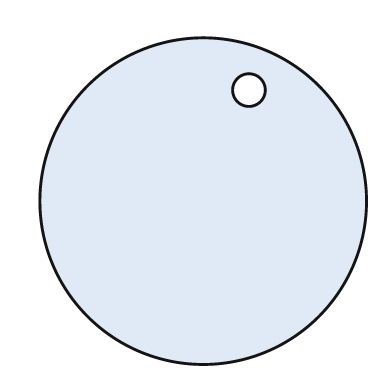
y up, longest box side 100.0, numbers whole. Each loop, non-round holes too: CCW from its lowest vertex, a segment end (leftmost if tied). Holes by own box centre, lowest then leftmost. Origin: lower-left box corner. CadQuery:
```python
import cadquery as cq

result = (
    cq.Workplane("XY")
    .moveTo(50.0, 50.0)
    .circle(50.0)
    .moveTo(64.0, 84.0)
    .circle(5.0)
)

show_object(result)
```